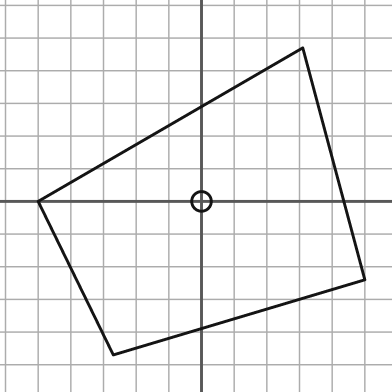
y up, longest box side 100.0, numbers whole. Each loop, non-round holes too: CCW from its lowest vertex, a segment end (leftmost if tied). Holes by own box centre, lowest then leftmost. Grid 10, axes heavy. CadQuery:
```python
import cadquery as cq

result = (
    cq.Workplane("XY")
    .moveTo(-27.0, -47.0)
    .lineTo(50.0, -24.0)
    .lineTo(31.0, 47.0)
    .lineTo(-50.0, 0.0)
    .close()
    .moveTo(0.0, 0.0)
    .circle(3.0)
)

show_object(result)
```